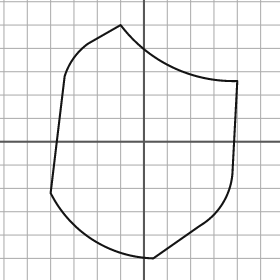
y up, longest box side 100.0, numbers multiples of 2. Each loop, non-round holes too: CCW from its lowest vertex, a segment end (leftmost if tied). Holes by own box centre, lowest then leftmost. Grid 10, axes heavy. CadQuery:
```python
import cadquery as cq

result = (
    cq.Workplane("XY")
    .moveTo(4.0, -50.0)
    .lineTo(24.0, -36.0)
    .threePointArc((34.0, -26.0), (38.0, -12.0))
    .lineTo(40.0, 26.0)
    .threePointArc((12.0, 32.0), (-10.0, 50.0))
    .lineTo(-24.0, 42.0)
    .threePointArc((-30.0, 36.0), (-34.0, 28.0))
    .lineTo(-40.0, -22.0)
    .threePointArc((-22.0, -42.0), (4.0, -50.0))
    .close()
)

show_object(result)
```